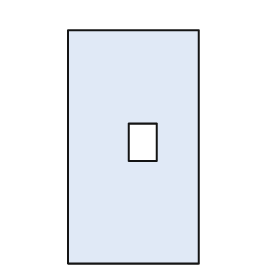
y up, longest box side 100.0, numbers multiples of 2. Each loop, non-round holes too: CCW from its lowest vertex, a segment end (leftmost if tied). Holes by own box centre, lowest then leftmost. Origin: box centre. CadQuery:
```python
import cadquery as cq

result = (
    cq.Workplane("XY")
    .moveTo(-28.0, -50.0)
    .lineTo(28.0, -50.0)
    .lineTo(28.0, 50.0)
    .lineTo(-28.0, 50.0)
    .close()
    .moveTo(-2.0, -6.0)
    .lineTo(10.0, -6.0)
    .lineTo(10.0, 10.0)
    .lineTo(-2.0, 10.0)
    .close()
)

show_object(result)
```